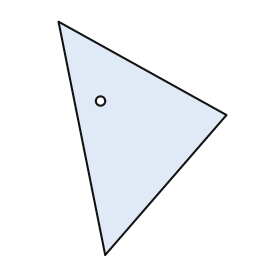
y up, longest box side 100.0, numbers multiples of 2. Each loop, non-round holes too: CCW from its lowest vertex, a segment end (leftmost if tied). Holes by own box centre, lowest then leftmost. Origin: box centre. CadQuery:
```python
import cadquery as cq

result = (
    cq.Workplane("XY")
    .moveTo(-16.0, -50.0)
    .lineTo(36.0, 10.0)
    .lineTo(-36.0, 50.0)
    .close()
    .moveTo(-18.0, 16.0)
    .circle(2.0)
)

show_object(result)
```